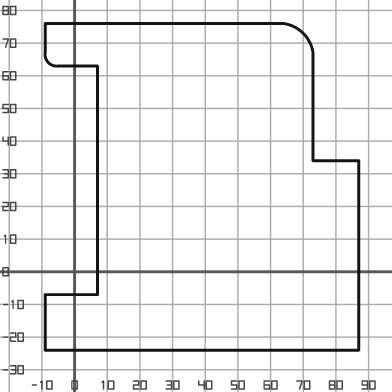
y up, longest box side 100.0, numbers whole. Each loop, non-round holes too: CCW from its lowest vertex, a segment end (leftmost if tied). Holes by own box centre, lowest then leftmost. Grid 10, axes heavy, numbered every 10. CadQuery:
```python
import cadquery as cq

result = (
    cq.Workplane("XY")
    .moveTo(-9.0, -24.0)
    .lineTo(87.0, -24.0)
    .lineTo(87.0, 34.0)
    .lineTo(73.0, 34.0)
    .lineTo(73.0, 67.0)
    .threePointArc((70.0, 73.0), (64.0, 76.0))
    .lineTo(-9.0, 76.0)
    .lineTo(-9.0, 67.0)
    .threePointArc((-8.0, 64.0), (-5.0, 63.0))
    .lineTo(7.0, 63.0)
    .lineTo(7.0, -7.0)
    .lineTo(-9.0, -7.0)
    .close()
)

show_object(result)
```